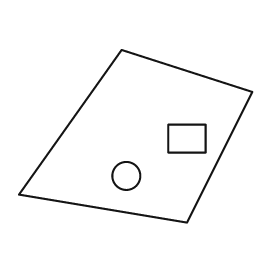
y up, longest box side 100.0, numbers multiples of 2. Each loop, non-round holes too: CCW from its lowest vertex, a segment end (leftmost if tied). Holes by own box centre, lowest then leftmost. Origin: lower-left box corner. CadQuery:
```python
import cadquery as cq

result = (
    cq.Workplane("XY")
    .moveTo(72.0, 0.0)
    .lineTo(100.0, 56.0)
    .lineTo(44.0, 74.0)
    .lineTo(0.0, 12.0)
    .close()
    .moveTo(46.0, 20.0)
    .circle(6.0)
    .moveTo(64.0, 30.0)
    .lineTo(80.0, 30.0)
    .lineTo(80.0, 42.0)
    .lineTo(64.0, 42.0)
    .close()
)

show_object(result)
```